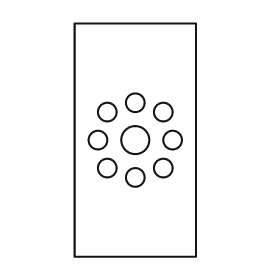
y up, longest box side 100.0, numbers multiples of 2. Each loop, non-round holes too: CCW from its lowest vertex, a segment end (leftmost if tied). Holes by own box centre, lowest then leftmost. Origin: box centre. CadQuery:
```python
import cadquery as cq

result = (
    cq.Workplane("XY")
    .moveTo(-26.0, -50.0)
    .lineTo(26.0, -50.0)
    .lineTo(26.0, 50.0)
    .lineTo(-26.0, 50.0)
    .close()
    .moveTo(0.0, -16.0)
    .circle(4.0)
    .moveTo(-12.0, -12.0)
    .circle(4.0)
    .moveTo(12.0, -12.0)
    .circle(4.0)
    .moveTo(-16.0, 0.0)
    .circle(4.0)
    .moveTo(0.0, 0.0)
    .circle(6.0)
    .moveTo(16.0, 0.0)
    .circle(4.0)
    .moveTo(-12.0, 12.0)
    .circle(4.0)
    .moveTo(12.0, 12.0)
    .circle(4.0)
    .moveTo(0.0, 16.0)
    .circle(4.0)
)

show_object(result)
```